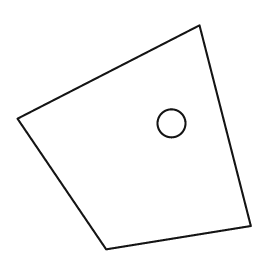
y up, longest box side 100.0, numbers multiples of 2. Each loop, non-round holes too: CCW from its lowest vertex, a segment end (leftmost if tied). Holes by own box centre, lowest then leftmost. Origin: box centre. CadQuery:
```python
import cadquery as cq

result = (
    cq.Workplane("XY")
    .moveTo(-12.0, -48.0)
    .lineTo(50.0, -38.0)
    .lineTo(28.0, 48.0)
    .lineTo(-50.0, 8.0)
    .close()
    .moveTo(16.0, 6.0)
    .circle(6.0)
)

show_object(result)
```